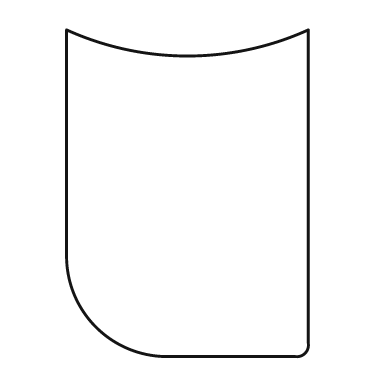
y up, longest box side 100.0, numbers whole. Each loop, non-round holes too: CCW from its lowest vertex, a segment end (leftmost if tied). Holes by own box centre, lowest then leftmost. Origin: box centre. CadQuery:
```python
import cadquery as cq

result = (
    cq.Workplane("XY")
    .moveTo(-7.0, -50.0)
    .lineTo(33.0, -50.0)
    .threePointArc((36.0, -49.0), (37.0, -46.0))
    .lineTo(37.0, 50.0)
    .threePointArc((0.0, 42.0), (-37.0, 50.0))
    .lineTo(-37.0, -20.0)
    .threePointArc((-28.0, -41.0), (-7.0, -50.0))
    .close()
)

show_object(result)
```